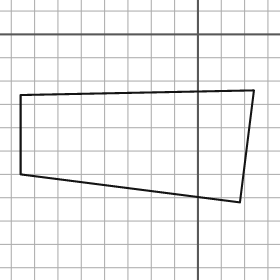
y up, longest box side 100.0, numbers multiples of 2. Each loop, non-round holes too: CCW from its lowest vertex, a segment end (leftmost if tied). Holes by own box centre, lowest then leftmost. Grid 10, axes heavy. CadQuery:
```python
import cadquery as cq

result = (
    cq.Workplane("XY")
    .moveTo(18.0, -72.0)
    .lineTo(24.0, -24.0)
    .lineTo(-76.0, -26.0)
    .lineTo(-76.0, -60.0)
    .close()
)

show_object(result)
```